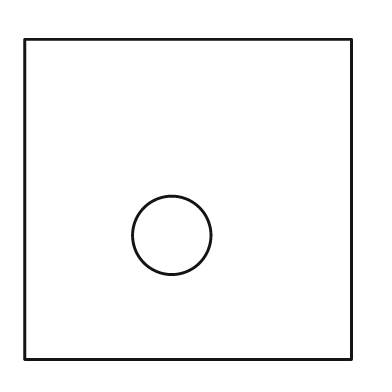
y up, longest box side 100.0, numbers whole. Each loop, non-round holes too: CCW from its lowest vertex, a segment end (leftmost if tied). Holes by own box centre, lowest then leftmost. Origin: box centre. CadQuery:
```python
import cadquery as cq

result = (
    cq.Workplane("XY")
    .moveTo(-50.0, -49.0)
    .lineTo(50.0, -49.0)
    .lineTo(50.0, 49.0)
    .lineTo(-50.0, 49.0)
    .close()
    .moveTo(-5.0, -11.0)
    .circle(12.0)
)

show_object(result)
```